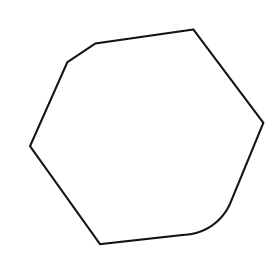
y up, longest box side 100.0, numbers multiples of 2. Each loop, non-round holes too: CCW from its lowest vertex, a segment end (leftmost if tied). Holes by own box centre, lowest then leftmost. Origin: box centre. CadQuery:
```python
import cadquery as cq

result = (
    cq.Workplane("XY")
    .moveTo(-20.0, -46.0)
    .lineTo(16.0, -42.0)
    .threePointArc((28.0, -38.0), (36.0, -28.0))
    .lineTo(50.0, 6.0)
    .lineTo(20.0, 46.0)
    .lineTo(-22.0, 40.0)
    .lineTo(-34.0, 32.0)
    .lineTo(-50.0, -4.0)
    .close()
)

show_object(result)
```